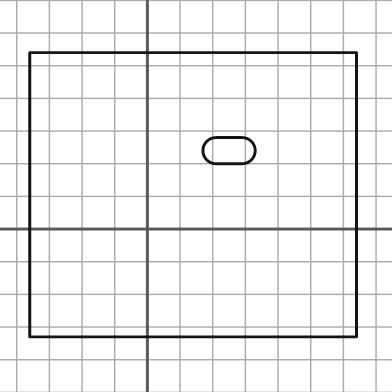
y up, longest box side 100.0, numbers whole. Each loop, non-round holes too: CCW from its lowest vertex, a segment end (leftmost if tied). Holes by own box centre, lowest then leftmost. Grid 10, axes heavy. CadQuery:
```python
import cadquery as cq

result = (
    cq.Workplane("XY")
    .moveTo(-36.0, -33.0)
    .lineTo(64.0, -33.0)
    .lineTo(64.0, 54.0)
    .lineTo(-36.0, 54.0)
    .close()
    .moveTo(21.0, 20.0)
    .lineTo(29.0, 20.0)
    .threePointArc((33.0, 24.0), (29.0, 28.0))
    .lineTo(21.0, 28.0)
    .threePointArc((17.0, 24.0), (21.0, 20.0))
    .close()
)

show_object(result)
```